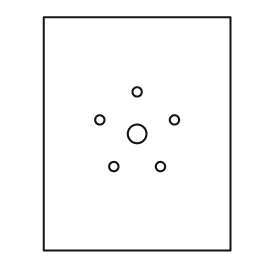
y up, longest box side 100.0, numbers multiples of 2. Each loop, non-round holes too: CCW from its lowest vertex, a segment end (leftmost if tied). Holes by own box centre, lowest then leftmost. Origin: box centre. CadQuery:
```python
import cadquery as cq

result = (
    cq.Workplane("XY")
    .moveTo(-40.0, -50.0)
    .lineTo(40.0, -50.0)
    .lineTo(40.0, 50.0)
    .lineTo(-40.0, 50.0)
    .close()
    .moveTo(-10.0, -14.0)
    .circle(2.0)
    .moveTo(10.0, -14.0)
    .circle(2.0)
    .moveTo(0.0, 0.0)
    .circle(4.0)
    .moveTo(-16.0, 6.0)
    .circle(2.0)
    .moveTo(16.0, 6.0)
    .circle(2.0)
    .moveTo(0.0, 18.0)
    .circle(2.0)
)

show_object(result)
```